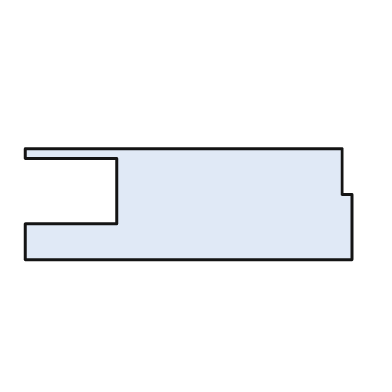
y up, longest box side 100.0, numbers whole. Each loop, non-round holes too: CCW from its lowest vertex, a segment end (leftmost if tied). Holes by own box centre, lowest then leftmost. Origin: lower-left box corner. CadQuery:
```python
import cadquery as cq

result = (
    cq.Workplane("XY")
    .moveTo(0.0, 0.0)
    .lineTo(100.0, 0.0)
    .lineTo(100.0, 20.0)
    .lineTo(97.0, 20.0)
    .lineTo(97.0, 34.0)
    .lineTo(0.0, 34.0)
    .lineTo(0.0, 31.0)
    .lineTo(28.0, 31.0)
    .lineTo(28.0, 11.0)
    .lineTo(0.0, 11.0)
    .close()
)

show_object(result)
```